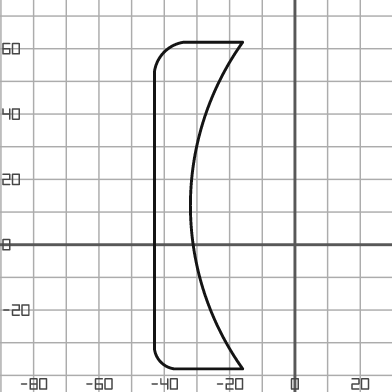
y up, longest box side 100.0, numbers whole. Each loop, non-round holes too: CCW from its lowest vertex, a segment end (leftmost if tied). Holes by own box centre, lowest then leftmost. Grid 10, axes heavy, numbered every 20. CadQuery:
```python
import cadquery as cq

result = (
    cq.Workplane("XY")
    .moveTo(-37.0, -38.0)
    .lineTo(-16.0, -38.0)
    .threePointArc((-32.0, 12.0), (-16.0, 62.0))
    .lineTo(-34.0, 62.0)
    .threePointArc((-40.0, 59.0), (-43.0, 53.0))
    .lineTo(-43.0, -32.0)
    .threePointArc((-41.0, -36.0), (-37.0, -38.0))
    .close()
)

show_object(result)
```